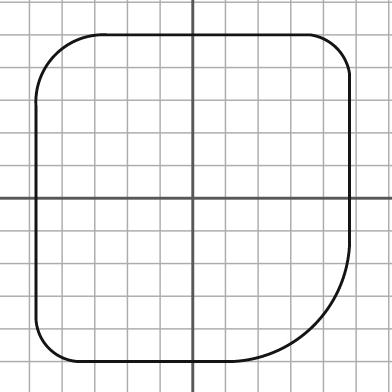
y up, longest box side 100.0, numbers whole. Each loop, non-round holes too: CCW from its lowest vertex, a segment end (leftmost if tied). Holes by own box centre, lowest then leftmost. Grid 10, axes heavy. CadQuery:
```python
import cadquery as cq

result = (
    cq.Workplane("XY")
    .moveTo(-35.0, -50.0)
    .lineTo(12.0, -50.0)
    .threePointArc((37.0, -39.0), (48.0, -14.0))
    .lineTo(48.0, 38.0)
    .threePointArc((44.0, 46.0), (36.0, 50.0))
    .lineTo(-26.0, 50.0)
    .threePointArc((-42.0, 44.0), (-48.0, 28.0))
    .lineTo(-48.0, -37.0)
    .threePointArc((-44.0, -46.0), (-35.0, -50.0))
    .close()
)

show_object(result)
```